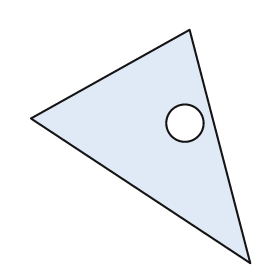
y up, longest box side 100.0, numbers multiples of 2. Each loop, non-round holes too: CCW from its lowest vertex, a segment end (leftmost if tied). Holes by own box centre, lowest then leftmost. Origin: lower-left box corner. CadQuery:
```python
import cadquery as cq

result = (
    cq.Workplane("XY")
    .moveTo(94.0, 0.0)
    .lineTo(68.0, 100.0)
    .lineTo(0.0, 62.0)
    .close()
    .moveTo(66.0, 60.0)
    .circle(8.0)
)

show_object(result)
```